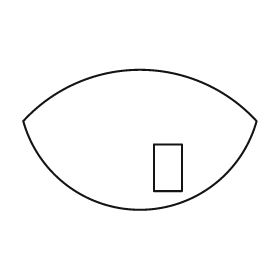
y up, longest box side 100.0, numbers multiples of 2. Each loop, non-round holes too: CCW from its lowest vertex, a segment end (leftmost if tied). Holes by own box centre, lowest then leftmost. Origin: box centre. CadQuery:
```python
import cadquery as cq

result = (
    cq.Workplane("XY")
    .moveTo(-50.0, 8.0)
    .threePointArc((0.0, -30.0), (50.0, 8.0))
    .threePointArc((0.0, 30.0), (-50.0, 8.0))
    .close()
    .moveTo(6.0, -22.0)
    .lineTo(18.0, -22.0)
    .lineTo(18.0, -2.0)
    .lineTo(6.0, -2.0)
    .close()
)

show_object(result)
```